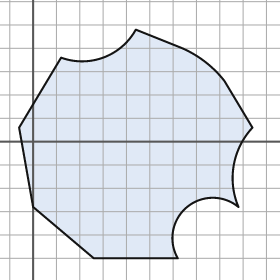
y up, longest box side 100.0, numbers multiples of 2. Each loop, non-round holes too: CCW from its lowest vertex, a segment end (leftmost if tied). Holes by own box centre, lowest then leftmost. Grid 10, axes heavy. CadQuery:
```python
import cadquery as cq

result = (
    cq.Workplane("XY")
    .moveTo(26.0, -50.0)
    .lineTo(62.0, -50.0)
    .threePointArc((66.0, -28.0), (88.0, -28.0))
    .threePointArc((86.0, -10.0), (94.0, 6.0))
    .lineTo(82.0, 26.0)
    .threePointArc((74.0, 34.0), (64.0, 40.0))
    .lineTo(44.0, 48.0)
    .threePointArc((30.0, 36.0), (12.0, 36.0))
    .lineTo(-6.0, 6.0)
    .lineTo(0.0, -28.0)
    .close()
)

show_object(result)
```